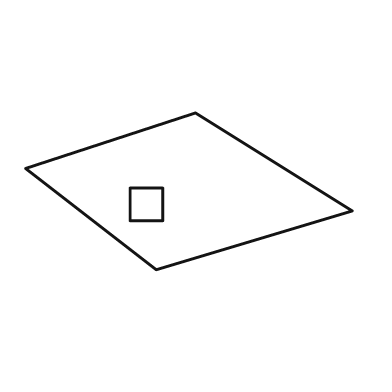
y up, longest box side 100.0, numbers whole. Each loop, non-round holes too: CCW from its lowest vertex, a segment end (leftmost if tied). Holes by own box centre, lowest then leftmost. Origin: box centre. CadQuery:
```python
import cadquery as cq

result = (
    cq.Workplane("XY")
    .moveTo(-10.0, -24.0)
    .lineTo(50.0, -6.0)
    .lineTo(2.0, 24.0)
    .lineTo(-50.0, 7.0)
    .close()
    .moveTo(-18.0, -9.0)
    .lineTo(-8.0, -9.0)
    .lineTo(-8.0, 1.0)
    .lineTo(-18.0, 1.0)
    .close()
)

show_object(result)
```